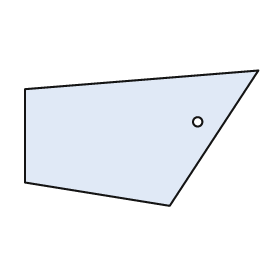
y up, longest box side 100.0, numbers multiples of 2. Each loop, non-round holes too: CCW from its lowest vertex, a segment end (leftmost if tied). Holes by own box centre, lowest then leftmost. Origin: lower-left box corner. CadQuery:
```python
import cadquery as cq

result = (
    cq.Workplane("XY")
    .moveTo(62.0, 0.0)
    .lineTo(100.0, 58.0)
    .lineTo(0.0, 50.0)
    .lineTo(0.0, 10.0)
    .close()
    .moveTo(74.0, 36.0)
    .circle(2.0)
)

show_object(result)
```